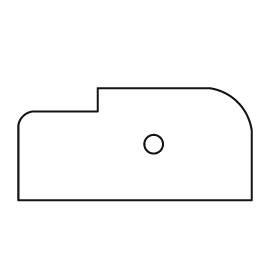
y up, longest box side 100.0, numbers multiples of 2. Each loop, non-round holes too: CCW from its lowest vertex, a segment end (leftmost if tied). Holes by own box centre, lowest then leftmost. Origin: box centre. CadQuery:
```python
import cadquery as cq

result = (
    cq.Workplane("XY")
    .moveTo(-50.0, -24.0)
    .lineTo(50.0, -24.0)
    .lineTo(50.0, 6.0)
    .threePointArc((44.0, 18.0), (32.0, 24.0))
    .lineTo(-16.0, 24.0)
    .lineTo(-16.0, 14.0)
    .lineTo(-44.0, 14.0)
    .threePointArc((-48.0, 12.0), (-50.0, 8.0))
    .close()
    .moveTo(8.0, 0.0)
    .circle(4.0)
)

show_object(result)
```